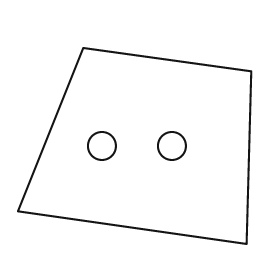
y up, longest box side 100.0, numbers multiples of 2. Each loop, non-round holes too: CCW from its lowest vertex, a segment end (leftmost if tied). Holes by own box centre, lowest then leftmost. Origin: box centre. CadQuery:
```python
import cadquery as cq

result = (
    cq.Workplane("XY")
    .moveTo(48.0, -42.0)
    .lineTo(50.0, 32.0)
    .lineTo(-22.0, 42.0)
    .lineTo(-50.0, -28.0)
    .close()
    .moveTo(-14.0, 0.0)
    .circle(6.0)
    .moveTo(16.0, 0.0)
    .circle(6.0)
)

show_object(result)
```